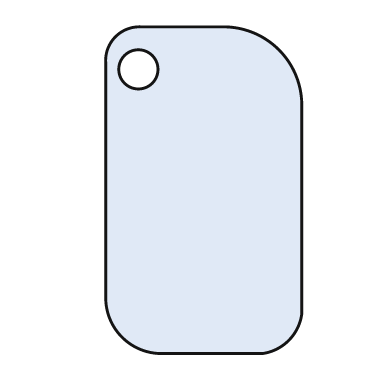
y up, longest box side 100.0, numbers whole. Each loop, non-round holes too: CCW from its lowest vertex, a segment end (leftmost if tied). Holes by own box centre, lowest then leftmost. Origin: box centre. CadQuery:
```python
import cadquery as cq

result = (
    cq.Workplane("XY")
    .moveTo(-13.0, -50.0)
    .lineTo(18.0, -50.0)
    .threePointArc((26.0, -46.0), (30.0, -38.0))
    .lineTo(30.0, 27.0)
    .threePointArc((23.0, 43.0), (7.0, 50.0))
    .lineTo(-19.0, 50.0)
    .threePointArc((-27.0, 47.0), (-30.0, 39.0))
    .lineTo(-30.0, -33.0)
    .threePointArc((-25.0, -45.0), (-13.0, -50.0))
    .close()
    .moveTo(-20.0, 37.0)
    .circle(6.0)
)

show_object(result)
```